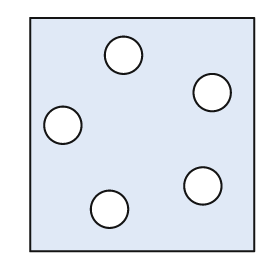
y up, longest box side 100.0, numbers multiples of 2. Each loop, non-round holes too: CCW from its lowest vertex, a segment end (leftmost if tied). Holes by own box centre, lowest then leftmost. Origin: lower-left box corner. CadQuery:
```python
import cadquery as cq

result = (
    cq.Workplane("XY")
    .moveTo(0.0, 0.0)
    .lineTo(96.0, 0.0)
    .lineTo(96.0, 100.0)
    .lineTo(0.0, 100.0)
    .close()
    .moveTo(34.0, 18.0)
    .circle(8.0)
    .moveTo(74.0, 28.0)
    .circle(8.0)
    .moveTo(14.0, 54.0)
    .circle(8.0)
    .moveTo(78.0, 68.0)
    .circle(8.0)
    .moveTo(40.0, 84.0)
    .circle(8.0)
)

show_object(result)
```